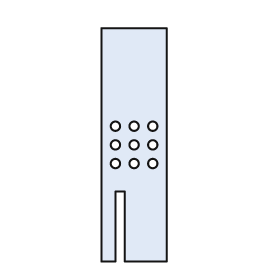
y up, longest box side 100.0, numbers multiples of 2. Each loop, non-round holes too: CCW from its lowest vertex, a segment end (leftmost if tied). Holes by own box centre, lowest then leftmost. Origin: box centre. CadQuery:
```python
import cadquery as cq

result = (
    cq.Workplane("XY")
    .moveTo(-14.0, -50.0)
    .lineTo(-8.0, -50.0)
    .lineTo(-8.0, -20.0)
    .lineTo(-4.0, -20.0)
    .lineTo(-4.0, -50.0)
    .lineTo(14.0, -50.0)
    .lineTo(14.0, 50.0)
    .lineTo(-14.0, 50.0)
    .close()
    .moveTo(-8.0, -8.0)
    .circle(2.0)
    .moveTo(0.0, -8.0)
    .circle(2.0)
    .moveTo(8.0, -8.0)
    .circle(2.0)
    .moveTo(-8.0, 0.0)
    .circle(2.0)
    .moveTo(0.0, 0.0)
    .circle(2.0)
    .moveTo(8.0, 0.0)
    .circle(2.0)
    .moveTo(-8.0, 8.0)
    .circle(2.0)
    .moveTo(0.0, 8.0)
    .circle(2.0)
    .moveTo(8.0, 8.0)
    .circle(2.0)
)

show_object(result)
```